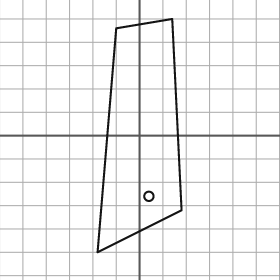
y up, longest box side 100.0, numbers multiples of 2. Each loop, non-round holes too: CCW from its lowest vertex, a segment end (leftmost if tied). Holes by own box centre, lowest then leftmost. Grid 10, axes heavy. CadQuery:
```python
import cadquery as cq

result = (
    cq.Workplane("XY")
    .moveTo(-18.0, -50.0)
    .lineTo(18.0, -32.0)
    .lineTo(14.0, 50.0)
    .lineTo(-10.0, 46.0)
    .close()
    .moveTo(4.0, -26.0)
    .circle(2.0)
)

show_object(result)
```